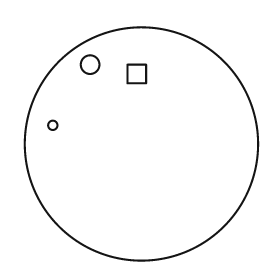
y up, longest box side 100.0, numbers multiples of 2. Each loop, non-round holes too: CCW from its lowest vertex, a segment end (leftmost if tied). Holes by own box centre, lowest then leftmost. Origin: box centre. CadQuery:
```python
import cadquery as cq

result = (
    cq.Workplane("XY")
    .moveTo(0.0, 0.0)
    .circle(50.0)
    .moveTo(-38.0, 8.0)
    .circle(2.0)
    .moveTo(-6.0, 26.0)
    .lineTo(2.0, 26.0)
    .lineTo(2.0, 34.0)
    .lineTo(-6.0, 34.0)
    .close()
    .moveTo(-22.0, 34.0)
    .circle(4.0)
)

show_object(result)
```